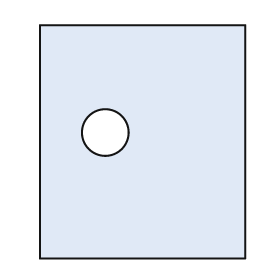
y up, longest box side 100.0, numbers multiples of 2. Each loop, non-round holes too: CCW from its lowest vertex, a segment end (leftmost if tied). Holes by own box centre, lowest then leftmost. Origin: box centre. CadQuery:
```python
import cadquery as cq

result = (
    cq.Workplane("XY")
    .moveTo(-44.0, -50.0)
    .lineTo(44.0, -50.0)
    .lineTo(44.0, 50.0)
    .lineTo(-44.0, 50.0)
    .close()
    .moveTo(-16.0, 4.0)
    .circle(10.0)
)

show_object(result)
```